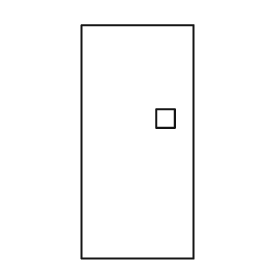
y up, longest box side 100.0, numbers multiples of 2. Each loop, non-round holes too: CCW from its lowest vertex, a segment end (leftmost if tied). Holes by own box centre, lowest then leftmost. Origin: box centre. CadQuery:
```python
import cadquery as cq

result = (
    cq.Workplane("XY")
    .moveTo(-24.0, -50.0)
    .lineTo(24.0, -50.0)
    .lineTo(24.0, 50.0)
    .lineTo(-24.0, 50.0)
    .close()
    .moveTo(8.0, 6.0)
    .lineTo(16.0, 6.0)
    .lineTo(16.0, 14.0)
    .lineTo(8.0, 14.0)
    .close()
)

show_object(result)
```